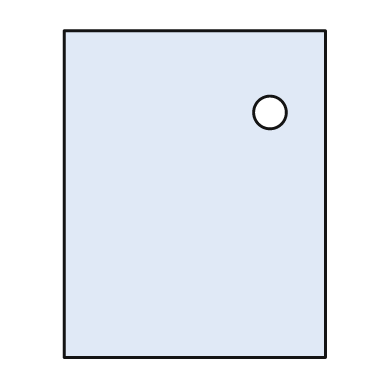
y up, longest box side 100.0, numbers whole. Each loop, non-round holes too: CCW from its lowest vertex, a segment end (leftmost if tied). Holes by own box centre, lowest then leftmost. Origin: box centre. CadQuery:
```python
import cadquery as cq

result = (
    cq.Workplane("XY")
    .moveTo(-40.0, -50.0)
    .lineTo(40.0, -50.0)
    .lineTo(40.0, 50.0)
    .lineTo(-40.0, 50.0)
    .close()
    .moveTo(23.0, 25.0)
    .circle(5.0)
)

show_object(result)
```